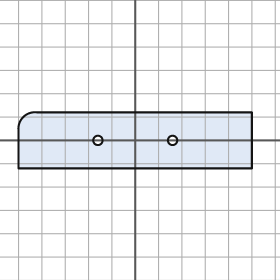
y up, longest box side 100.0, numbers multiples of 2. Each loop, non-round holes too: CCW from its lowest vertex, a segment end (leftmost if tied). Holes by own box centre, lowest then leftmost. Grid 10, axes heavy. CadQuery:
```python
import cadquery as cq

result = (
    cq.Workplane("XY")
    .moveTo(-50.0, -12.0)
    .lineTo(50.0, -12.0)
    .lineTo(50.0, 12.0)
    .lineTo(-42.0, 12.0)
    .threePointArc((-48.0, 10.0), (-50.0, 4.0))
    .close()
    .moveTo(-16.0, 0.0)
    .circle(2.0)
    .moveTo(16.0, 0.0)
    .circle(2.0)
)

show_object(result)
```